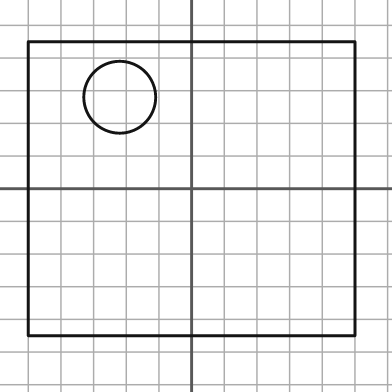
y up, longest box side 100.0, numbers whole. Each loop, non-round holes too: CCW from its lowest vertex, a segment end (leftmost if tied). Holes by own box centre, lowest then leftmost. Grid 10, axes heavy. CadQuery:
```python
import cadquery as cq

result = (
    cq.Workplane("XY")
    .moveTo(-50.0, -45.0)
    .lineTo(50.0, -45.0)
    .lineTo(50.0, 45.0)
    .lineTo(-50.0, 45.0)
    .close()
    .moveTo(-22.0, 28.0)
    .circle(11.0)
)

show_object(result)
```